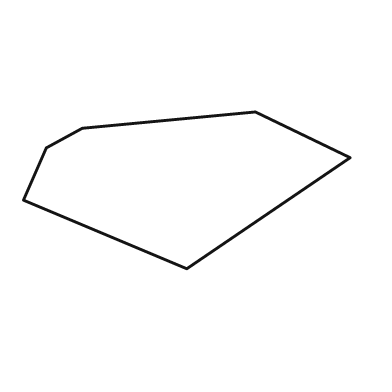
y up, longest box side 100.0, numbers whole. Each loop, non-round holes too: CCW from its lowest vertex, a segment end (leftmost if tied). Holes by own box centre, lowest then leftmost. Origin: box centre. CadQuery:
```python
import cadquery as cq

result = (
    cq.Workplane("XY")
    .moveTo(0.0, -24.0)
    .lineTo(50.0, 10.0)
    .lineTo(21.0, 24.0)
    .lineTo(-32.0, 19.0)
    .lineTo(-43.0, 13.0)
    .lineTo(-50.0, -3.0)
    .close()
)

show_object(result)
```